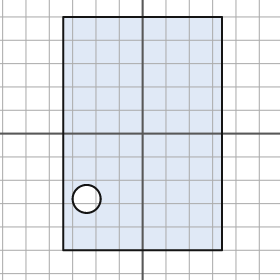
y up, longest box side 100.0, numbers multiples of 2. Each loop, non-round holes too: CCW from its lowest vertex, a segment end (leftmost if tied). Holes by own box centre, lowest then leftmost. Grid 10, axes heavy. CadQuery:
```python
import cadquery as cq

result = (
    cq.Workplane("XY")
    .moveTo(-34.0, -50.0)
    .lineTo(34.0, -50.0)
    .lineTo(34.0, 50.0)
    .lineTo(-34.0, 50.0)
    .close()
    .moveTo(-24.0, -28.0)
    .circle(6.0)
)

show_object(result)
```